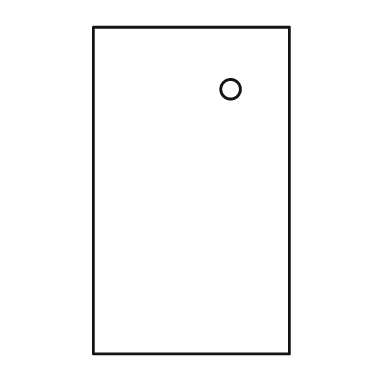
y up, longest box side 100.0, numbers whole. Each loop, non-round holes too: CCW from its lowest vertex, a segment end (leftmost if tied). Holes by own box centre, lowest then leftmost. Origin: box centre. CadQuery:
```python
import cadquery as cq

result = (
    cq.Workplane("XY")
    .moveTo(-30.0, -50.0)
    .lineTo(30.0, -50.0)
    .lineTo(30.0, 50.0)
    .lineTo(-30.0, 50.0)
    .close()
    .moveTo(12.0, 31.0)
    .circle(3.0)
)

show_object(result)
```